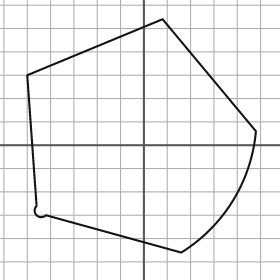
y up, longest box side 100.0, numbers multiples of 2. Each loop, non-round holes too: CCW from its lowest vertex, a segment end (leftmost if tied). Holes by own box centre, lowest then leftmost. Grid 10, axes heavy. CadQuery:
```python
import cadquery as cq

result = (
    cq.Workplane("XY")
    .moveTo(16.0, -46.0)
    .threePointArc((38.0, -24.0), (48.0, 6.0))
    .lineTo(8.0, 54.0)
    .lineTo(-50.0, 30.0)
    .lineTo(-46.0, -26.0)
    .threePointArc((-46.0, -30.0), (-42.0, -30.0))
    .close()
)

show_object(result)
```